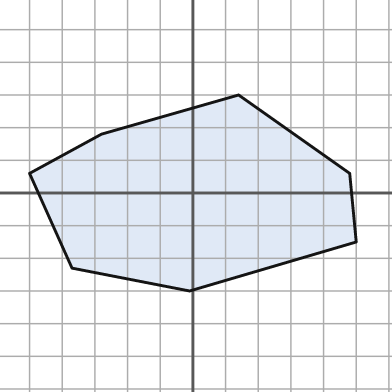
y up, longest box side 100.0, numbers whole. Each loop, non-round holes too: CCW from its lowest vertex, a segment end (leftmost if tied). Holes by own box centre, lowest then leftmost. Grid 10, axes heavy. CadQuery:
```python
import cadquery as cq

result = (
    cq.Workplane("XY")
    .moveTo(-1.0, -30.0)
    .lineTo(50.0, -15.0)
    .lineTo(48.0, 6.0)
    .lineTo(14.0, 30.0)
    .lineTo(-28.0, 18.0)
    .lineTo(-50.0, 6.0)
    .lineTo(-37.0, -23.0)
    .close()
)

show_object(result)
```